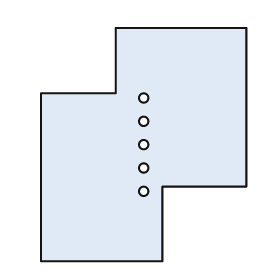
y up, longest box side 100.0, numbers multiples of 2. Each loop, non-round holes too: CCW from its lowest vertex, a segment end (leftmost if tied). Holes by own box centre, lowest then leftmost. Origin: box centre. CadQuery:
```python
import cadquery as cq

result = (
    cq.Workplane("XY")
    .moveTo(-44.0, -50.0)
    .lineTo(8.0, -50.0)
    .lineTo(8.0, -18.0)
    .lineTo(44.0, -18.0)
    .lineTo(44.0, 50.0)
    .lineTo(-12.0, 50.0)
    .lineTo(-12.0, 22.0)
    .lineTo(-44.0, 22.0)
    .close()
    .moveTo(0.0, -20.0)
    .circle(2.0)
    .moveTo(0.0, -10.0)
    .circle(2.0)
    .moveTo(0.0, 0.0)
    .circle(2.0)
    .moveTo(0.0, 10.0)
    .circle(2.0)
    .moveTo(0.0, 20.0)
    .circle(2.0)
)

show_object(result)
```